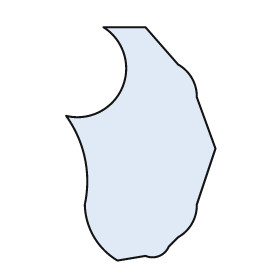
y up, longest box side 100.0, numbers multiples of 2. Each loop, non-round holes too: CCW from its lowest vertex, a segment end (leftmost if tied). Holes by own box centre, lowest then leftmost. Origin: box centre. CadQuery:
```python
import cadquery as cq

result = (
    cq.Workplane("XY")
    .moveTo(-10.0, -50.0)
    .lineTo(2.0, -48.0)
    .threePointArc((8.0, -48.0), (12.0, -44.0))
    .lineTo(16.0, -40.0)
    .threePointArc((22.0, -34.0), (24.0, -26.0))
    .lineTo(32.0, -2.0)
    .lineTo(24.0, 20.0)
    .threePointArc((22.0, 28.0), (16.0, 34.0))
    .lineTo(2.0, 50.0)
    .lineTo(-16.0, 50.0)
    .threePointArc((-8.0, 24.0), (-32.0, 12.0))
    .threePointArc((-24.0, -6.0), (-24.0, -26.0))
    .threePointArc((-20.0, -40.0), (-10.0, -50.0))
    .close()
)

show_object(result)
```